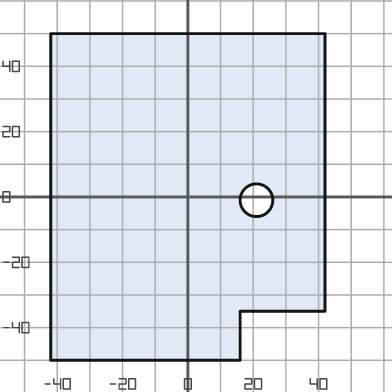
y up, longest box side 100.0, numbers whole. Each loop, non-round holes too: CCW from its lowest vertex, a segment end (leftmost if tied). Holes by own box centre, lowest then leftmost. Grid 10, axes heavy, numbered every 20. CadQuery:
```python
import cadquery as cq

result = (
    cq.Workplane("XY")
    .moveTo(-42.0, -50.0)
    .lineTo(16.0, -50.0)
    .lineTo(16.0, -35.0)
    .lineTo(42.0, -35.0)
    .lineTo(42.0, 50.0)
    .lineTo(-42.0, 50.0)
    .close()
    .moveTo(21.0, -1.0)
    .circle(5.0)
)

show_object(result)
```